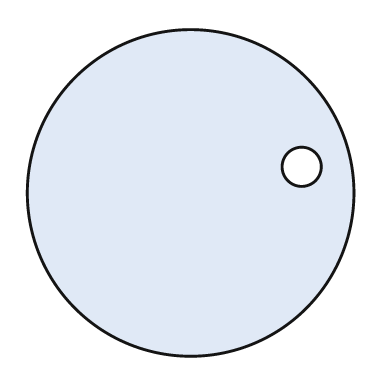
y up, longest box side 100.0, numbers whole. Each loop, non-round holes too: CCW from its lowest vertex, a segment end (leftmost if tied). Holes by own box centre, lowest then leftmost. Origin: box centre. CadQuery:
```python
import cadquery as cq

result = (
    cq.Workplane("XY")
    .moveTo(0.0, 0.0)
    .circle(50.0)
    .moveTo(34.0, 8.0)
    .circle(6.0)
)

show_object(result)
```